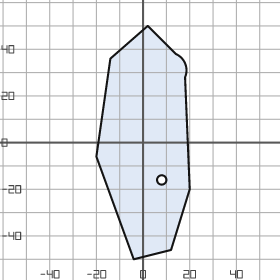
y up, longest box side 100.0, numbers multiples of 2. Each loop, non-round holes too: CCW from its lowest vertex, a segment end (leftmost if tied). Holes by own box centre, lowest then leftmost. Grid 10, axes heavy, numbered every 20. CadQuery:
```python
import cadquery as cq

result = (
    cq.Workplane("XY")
    .moveTo(-4.0, -50.0)
    .lineTo(12.0, -46.0)
    .lineTo(20.0, -20.0)
    .lineTo(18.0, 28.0)
    .threePointArc((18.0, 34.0), (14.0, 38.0))
    .lineTo(2.0, 50.0)
    .lineTo(-14.0, 36.0)
    .lineTo(-20.0, -6.0)
    .close()
    .moveTo(8.0, -16.0)
    .circle(2.0)
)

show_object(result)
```